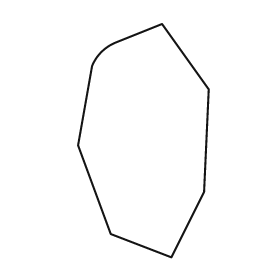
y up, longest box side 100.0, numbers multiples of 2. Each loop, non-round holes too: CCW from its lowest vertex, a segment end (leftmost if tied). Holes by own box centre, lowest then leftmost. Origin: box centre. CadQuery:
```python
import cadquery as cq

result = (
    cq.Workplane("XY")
    .moveTo(12.0, -50.0)
    .lineTo(26.0, -22.0)
    .lineTo(28.0, 22.0)
    .lineTo(8.0, 50.0)
    .lineTo(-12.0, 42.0)
    .threePointArc((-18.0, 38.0), (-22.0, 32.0))
    .lineTo(-28.0, -2.0)
    .lineTo(-14.0, -40.0)
    .close()
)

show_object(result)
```